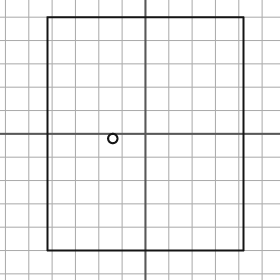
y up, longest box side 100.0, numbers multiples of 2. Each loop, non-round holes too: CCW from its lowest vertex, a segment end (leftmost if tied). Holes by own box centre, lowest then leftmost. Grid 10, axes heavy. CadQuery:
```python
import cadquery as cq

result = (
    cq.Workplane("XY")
    .moveTo(-42.0, -50.0)
    .lineTo(42.0, -50.0)
    .lineTo(42.0, 50.0)
    .lineTo(-42.0, 50.0)
    .close()
    .moveTo(-14.0, -2.0)
    .circle(2.0)
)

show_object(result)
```